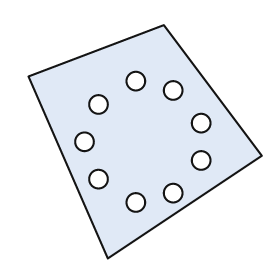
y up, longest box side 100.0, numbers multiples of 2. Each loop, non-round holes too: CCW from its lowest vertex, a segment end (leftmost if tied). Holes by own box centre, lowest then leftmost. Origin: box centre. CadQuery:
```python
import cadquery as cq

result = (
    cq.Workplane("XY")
    .moveTo(-16.0, -50.0)
    .lineTo(50.0, -6.0)
    .lineTo(8.0, 50.0)
    .lineTo(-50.0, 28.0)
    .close()
    .moveTo(-4.0, -26.0)
    .circle(4.0)
    .moveTo(12.0, -22.0)
    .circle(4.0)
    .moveTo(-20.0, -16.0)
    .circle(4.0)
    .moveTo(24.0, -8.0)
    .circle(4.0)
    .moveTo(-26.0, 0.0)
    .circle(4.0)
    .moveTo(24.0, 8.0)
    .circle(4.0)
    .moveTo(-20.0, 16.0)
    .circle(4.0)
    .moveTo(12.0, 22.0)
    .circle(4.0)
    .moveTo(-4.0, 26.0)
    .circle(4.0)
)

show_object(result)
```